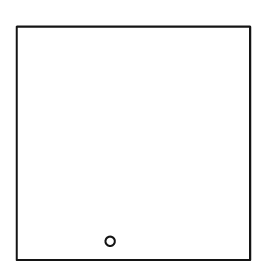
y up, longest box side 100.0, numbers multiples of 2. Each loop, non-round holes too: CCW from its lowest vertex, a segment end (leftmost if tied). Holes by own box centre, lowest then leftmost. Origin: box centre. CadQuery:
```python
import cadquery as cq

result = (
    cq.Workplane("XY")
    .moveTo(-50.0, -50.0)
    .lineTo(50.0, -50.0)
    .lineTo(50.0, 50.0)
    .lineTo(-50.0, 50.0)
    .close()
    .moveTo(-10.0, -42.0)
    .circle(2.0)
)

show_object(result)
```